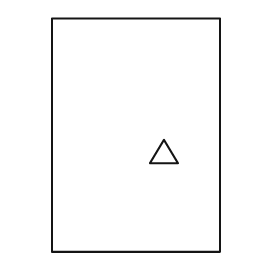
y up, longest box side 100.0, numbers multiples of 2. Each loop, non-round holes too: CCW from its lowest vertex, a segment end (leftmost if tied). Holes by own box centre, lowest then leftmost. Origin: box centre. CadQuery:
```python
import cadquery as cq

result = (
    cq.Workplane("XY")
    .moveTo(-36.0, -50.0)
    .lineTo(36.0, -50.0)
    .lineTo(36.0, 50.0)
    .lineTo(-36.0, 50.0)
    .close()
    .moveTo(6.0, -12.0)
    .lineTo(18.0, -12.0)
    .lineTo(12.0, -2.0)
    .close()
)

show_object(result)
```